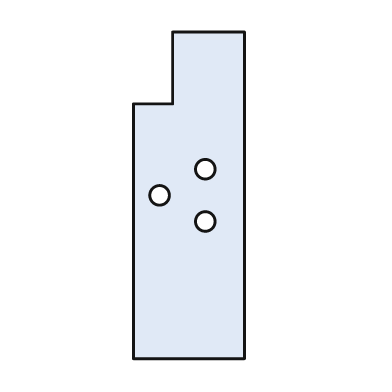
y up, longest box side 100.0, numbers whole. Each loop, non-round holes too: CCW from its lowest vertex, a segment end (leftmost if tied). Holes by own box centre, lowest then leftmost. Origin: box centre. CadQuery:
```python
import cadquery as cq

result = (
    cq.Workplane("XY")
    .moveTo(-17.0, -50.0)
    .lineTo(17.0, -50.0)
    .lineTo(17.0, 50.0)
    .lineTo(-5.0, 50.0)
    .lineTo(-5.0, 28.0)
    .lineTo(-17.0, 28.0)
    .close()
    .moveTo(5.0, -8.0)
    .circle(3.0)
    .moveTo(-9.0, 0.0)
    .circle(3.0)
    .moveTo(5.0, 8.0)
    .circle(3.0)
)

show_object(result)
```